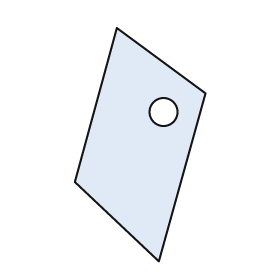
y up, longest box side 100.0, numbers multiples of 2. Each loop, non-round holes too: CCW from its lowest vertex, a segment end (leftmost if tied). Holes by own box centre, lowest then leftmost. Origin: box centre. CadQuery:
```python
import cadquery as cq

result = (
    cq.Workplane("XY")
    .moveTo(8.0, -50.0)
    .lineTo(28.0, 22.0)
    .lineTo(-10.0, 50.0)
    .lineTo(-28.0, -16.0)
    .close()
    .moveTo(10.0, 14.0)
    .circle(6.0)
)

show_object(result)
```